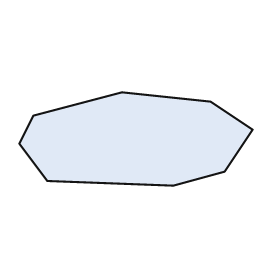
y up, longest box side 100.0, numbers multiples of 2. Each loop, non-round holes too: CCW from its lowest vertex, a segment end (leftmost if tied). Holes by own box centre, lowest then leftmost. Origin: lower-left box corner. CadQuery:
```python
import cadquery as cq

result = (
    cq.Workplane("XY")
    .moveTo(66.0, 0.0)
    .lineTo(88.0, 6.0)
    .lineTo(100.0, 24.0)
    .lineTo(82.0, 36.0)
    .lineTo(44.0, 40.0)
    .lineTo(6.0, 30.0)
    .lineTo(0.0, 18.0)
    .lineTo(12.0, 2.0)
    .close()
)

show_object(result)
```